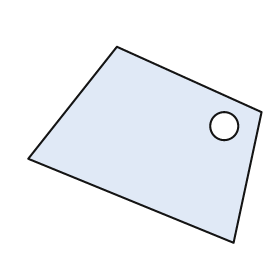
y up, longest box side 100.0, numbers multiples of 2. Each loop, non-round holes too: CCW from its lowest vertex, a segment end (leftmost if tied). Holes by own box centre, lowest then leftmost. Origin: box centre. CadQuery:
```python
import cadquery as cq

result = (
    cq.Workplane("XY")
    .moveTo(38.0, -42.0)
    .lineTo(50.0, 14.0)
    .lineTo(-12.0, 42.0)
    .lineTo(-50.0, -6.0)
    .close()
    .moveTo(34.0, 8.0)
    .circle(6.0)
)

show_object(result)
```